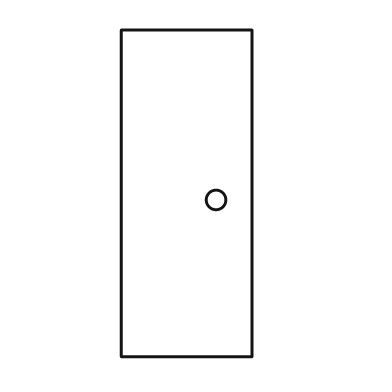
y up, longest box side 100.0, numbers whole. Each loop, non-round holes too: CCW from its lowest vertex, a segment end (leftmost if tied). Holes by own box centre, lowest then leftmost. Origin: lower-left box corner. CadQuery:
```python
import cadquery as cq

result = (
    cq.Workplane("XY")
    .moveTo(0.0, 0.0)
    .lineTo(40.0, 0.0)
    .lineTo(40.0, 100.0)
    .lineTo(0.0, 100.0)
    .close()
    .moveTo(29.0, 48.0)
    .circle(3.0)
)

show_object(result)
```